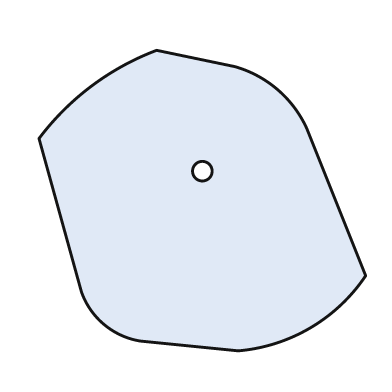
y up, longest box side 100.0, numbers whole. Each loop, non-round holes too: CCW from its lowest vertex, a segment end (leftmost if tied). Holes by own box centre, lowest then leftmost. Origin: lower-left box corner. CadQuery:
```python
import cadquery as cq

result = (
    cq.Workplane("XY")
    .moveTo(61.0, 0.0)
    .threePointArc((83.0, 7.0), (100.0, 23.0))
    .lineTo(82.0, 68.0)
    .threePointArc((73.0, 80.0), (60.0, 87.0))
    .lineTo(36.0, 92.0)
    .threePointArc((16.0, 81.0), (0.0, 65.0))
    .lineTo(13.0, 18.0)
    .threePointArc((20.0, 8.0), (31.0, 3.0))
    .close()
    .moveTo(50.0, 55.0)
    .circle(3.0)
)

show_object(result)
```